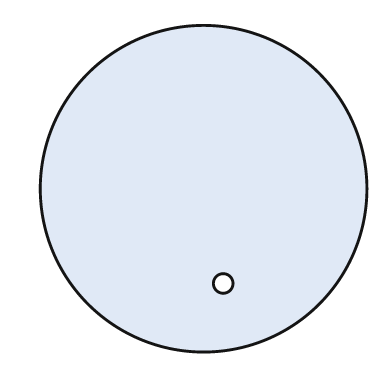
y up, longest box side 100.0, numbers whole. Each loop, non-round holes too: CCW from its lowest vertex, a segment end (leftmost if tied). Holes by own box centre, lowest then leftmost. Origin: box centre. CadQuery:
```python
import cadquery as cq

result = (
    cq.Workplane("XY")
    .moveTo(0.0, 0.0)
    .circle(50.0)
    .moveTo(6.0, -29.0)
    .circle(3.0)
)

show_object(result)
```